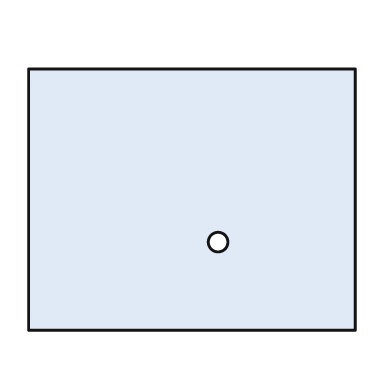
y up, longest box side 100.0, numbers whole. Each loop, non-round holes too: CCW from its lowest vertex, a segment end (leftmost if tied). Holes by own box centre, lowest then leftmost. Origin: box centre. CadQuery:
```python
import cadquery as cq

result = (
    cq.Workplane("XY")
    .moveTo(-50.0, -40.0)
    .lineTo(50.0, -40.0)
    .lineTo(50.0, 40.0)
    .lineTo(-50.0, 40.0)
    .close()
    .moveTo(8.0, -13.0)
    .circle(3.0)
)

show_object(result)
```